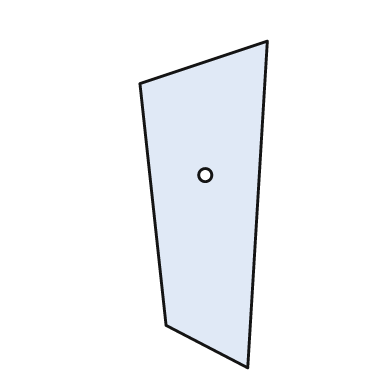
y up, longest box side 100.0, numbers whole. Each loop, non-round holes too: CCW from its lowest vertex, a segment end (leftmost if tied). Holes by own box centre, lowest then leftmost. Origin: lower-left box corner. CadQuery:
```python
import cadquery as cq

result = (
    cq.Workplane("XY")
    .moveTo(33.0, 0.0)
    .lineTo(39.0, 100.0)
    .lineTo(0.0, 87.0)
    .lineTo(8.0, 13.0)
    .close()
    .moveTo(20.0, 59.0)
    .circle(2.0)
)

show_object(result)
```